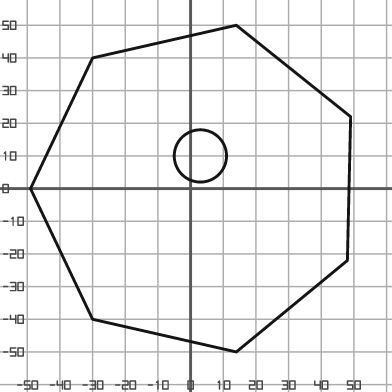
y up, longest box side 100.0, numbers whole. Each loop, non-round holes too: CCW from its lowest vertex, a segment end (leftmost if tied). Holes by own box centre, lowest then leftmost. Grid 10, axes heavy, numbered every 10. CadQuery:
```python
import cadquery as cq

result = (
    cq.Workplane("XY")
    .moveTo(14.0, -50.0)
    .lineTo(48.0, -22.0)
    .lineTo(49.0, 22.0)
    .lineTo(14.0, 50.0)
    .lineTo(-30.0, 40.0)
    .lineTo(-49.0, 0.0)
    .lineTo(-30.0, -40.0)
    .close()
    .moveTo(3.0, 10.0)
    .circle(8.0)
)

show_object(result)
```